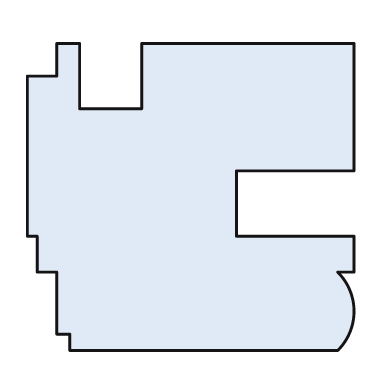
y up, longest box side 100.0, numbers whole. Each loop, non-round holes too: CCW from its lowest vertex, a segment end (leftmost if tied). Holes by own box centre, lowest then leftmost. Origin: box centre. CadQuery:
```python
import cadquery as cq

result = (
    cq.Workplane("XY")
    .moveTo(-37.0, -47.0)
    .lineTo(45.0, -47.0)
    .threePointArc((50.0, -35.0), (45.0, -23.0))
    .lineTo(50.0, -23.0)
    .lineTo(50.0, -12.0)
    .lineTo(14.0, -12.0)
    .lineTo(14.0, 8.0)
    .lineTo(50.0, 8.0)
    .lineTo(50.0, 47.0)
    .lineTo(-15.0, 47.0)
    .lineTo(-15.0, 27.0)
    .lineTo(-34.0, 27.0)
    .lineTo(-34.0, 47.0)
    .lineTo(-41.0, 47.0)
    .lineTo(-41.0, 37.0)
    .lineTo(-50.0, 37.0)
    .lineTo(-50.0, -12.0)
    .lineTo(-47.0, -12.0)
    .lineTo(-47.0, -23.0)
    .lineTo(-41.0, -23.0)
    .lineTo(-41.0, -42.0)
    .lineTo(-37.0, -42.0)
    .close()
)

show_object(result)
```